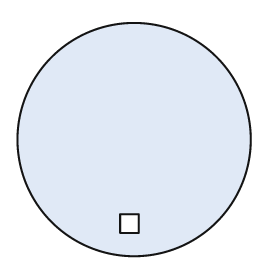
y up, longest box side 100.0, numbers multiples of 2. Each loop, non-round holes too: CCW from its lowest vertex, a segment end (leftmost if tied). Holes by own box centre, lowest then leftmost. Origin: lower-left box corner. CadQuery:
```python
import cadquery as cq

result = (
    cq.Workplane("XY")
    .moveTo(50.0, 50.0)
    .circle(50.0)
    .moveTo(44.0, 10.0)
    .lineTo(52.0, 10.0)
    .lineTo(52.0, 18.0)
    .lineTo(44.0, 18.0)
    .close()
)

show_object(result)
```